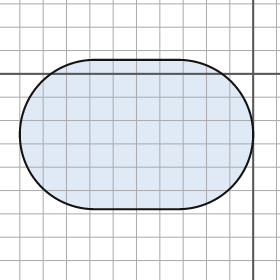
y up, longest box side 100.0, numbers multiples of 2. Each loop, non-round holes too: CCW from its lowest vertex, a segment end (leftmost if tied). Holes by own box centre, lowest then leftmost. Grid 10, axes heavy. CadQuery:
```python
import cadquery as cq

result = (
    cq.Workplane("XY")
    .moveTo(-68.0, -58.0)
    .lineTo(-32.0, -58.0)
    .threePointArc((0.0, -26.0), (-32.0, 6.0))
    .lineTo(-68.0, 6.0)
    .threePointArc((-100.0, -26.0), (-68.0, -58.0))
    .close()
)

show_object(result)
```